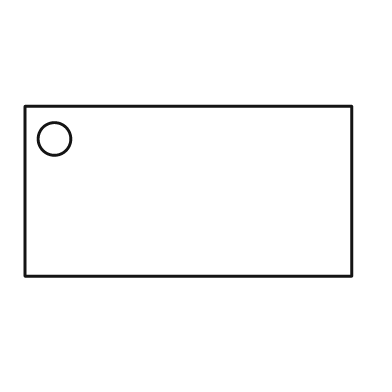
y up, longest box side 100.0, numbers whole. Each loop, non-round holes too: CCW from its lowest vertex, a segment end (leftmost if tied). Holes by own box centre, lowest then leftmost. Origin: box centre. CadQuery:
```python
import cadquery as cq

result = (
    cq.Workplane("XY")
    .moveTo(-50.0, -26.0)
    .lineTo(50.0, -26.0)
    .lineTo(50.0, 26.0)
    .lineTo(-50.0, 26.0)
    .close()
    .moveTo(-41.0, 16.0)
    .circle(5.0)
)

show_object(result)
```